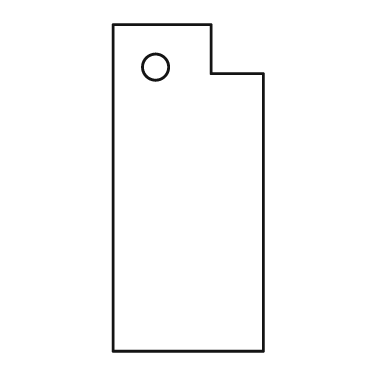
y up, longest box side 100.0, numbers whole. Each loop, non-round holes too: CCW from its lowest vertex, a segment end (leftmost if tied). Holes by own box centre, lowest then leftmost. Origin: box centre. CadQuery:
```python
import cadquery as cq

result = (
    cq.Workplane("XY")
    .moveTo(-23.0, -50.0)
    .lineTo(23.0, -50.0)
    .lineTo(23.0, 35.0)
    .lineTo(7.0, 35.0)
    .lineTo(7.0, 50.0)
    .lineTo(-23.0, 50.0)
    .close()
    .moveTo(-10.0, 37.0)
    .circle(4.0)
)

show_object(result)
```